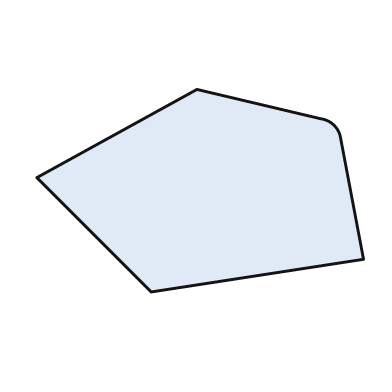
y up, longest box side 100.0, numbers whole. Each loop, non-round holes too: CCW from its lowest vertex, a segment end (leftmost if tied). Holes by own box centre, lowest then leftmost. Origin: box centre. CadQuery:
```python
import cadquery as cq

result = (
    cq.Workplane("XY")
    .moveTo(-15.0, -31.0)
    .lineTo(50.0, -21.0)
    .lineTo(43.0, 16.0)
    .threePointArc((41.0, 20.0), (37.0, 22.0))
    .lineTo(-1.0, 31.0)
    .lineTo(-50.0, 4.0)
    .close()
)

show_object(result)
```